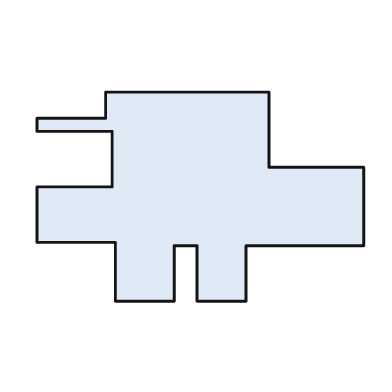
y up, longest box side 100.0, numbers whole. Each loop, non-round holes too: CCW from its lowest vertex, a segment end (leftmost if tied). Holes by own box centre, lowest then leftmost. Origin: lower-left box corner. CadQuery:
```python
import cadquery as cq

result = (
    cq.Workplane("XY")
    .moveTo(24.0, 0.0)
    .lineTo(42.0, 0.0)
    .lineTo(42.0, 17.0)
    .lineTo(49.0, 17.0)
    .lineTo(49.0, 0.0)
    .lineTo(64.0, 0.0)
    .lineTo(64.0, 17.0)
    .lineTo(100.0, 17.0)
    .lineTo(100.0, 41.0)
    .lineTo(71.0, 41.0)
    .lineTo(71.0, 64.0)
    .lineTo(21.0, 64.0)
    .lineTo(21.0, 56.0)
    .lineTo(0.0, 56.0)
    .lineTo(0.0, 52.0)
    .lineTo(23.0, 52.0)
    .lineTo(23.0, 35.0)
    .lineTo(0.0, 35.0)
    .lineTo(0.0, 18.0)
    .lineTo(24.0, 18.0)
    .close()
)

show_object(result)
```